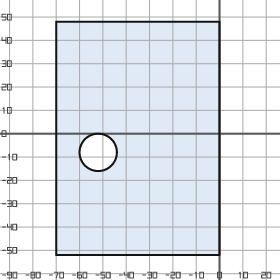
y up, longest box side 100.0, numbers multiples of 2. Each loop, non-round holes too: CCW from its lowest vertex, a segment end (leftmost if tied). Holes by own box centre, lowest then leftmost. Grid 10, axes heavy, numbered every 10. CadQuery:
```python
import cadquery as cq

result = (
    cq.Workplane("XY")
    .moveTo(-70.0, -52.0)
    .lineTo(0.0, -52.0)
    .lineTo(0.0, 48.0)
    .lineTo(-70.0, 48.0)
    .close()
    .moveTo(-52.0, -8.0)
    .circle(8.0)
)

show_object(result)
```